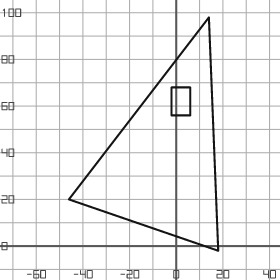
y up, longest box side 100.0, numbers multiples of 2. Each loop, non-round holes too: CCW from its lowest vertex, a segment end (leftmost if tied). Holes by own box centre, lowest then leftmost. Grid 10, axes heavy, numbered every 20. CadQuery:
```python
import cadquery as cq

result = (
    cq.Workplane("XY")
    .moveTo(18.0, -2.0)
    .lineTo(14.0, 98.0)
    .lineTo(-46.0, 20.0)
    .close()
    .moveTo(-2.0, 56.0)
    .lineTo(6.0, 56.0)
    .lineTo(6.0, 68.0)
    .lineTo(-2.0, 68.0)
    .close()
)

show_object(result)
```